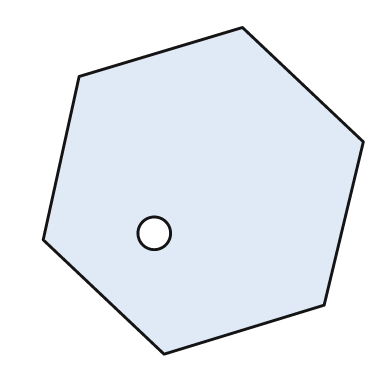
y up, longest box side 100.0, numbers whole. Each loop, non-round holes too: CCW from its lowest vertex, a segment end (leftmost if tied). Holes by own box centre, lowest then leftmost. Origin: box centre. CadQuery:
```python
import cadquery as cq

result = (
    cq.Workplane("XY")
    .moveTo(-12.0, -50.0)
    .lineTo(37.0, -35.0)
    .lineTo(49.0, 15.0)
    .lineTo(12.0, 50.0)
    .lineTo(-38.0, 35.0)
    .lineTo(-49.0, -15.0)
    .close()
    .moveTo(-15.0, -13.0)
    .circle(5.0)
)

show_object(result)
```